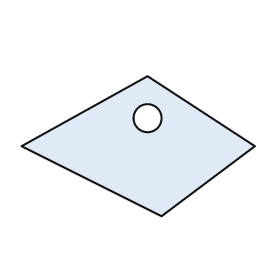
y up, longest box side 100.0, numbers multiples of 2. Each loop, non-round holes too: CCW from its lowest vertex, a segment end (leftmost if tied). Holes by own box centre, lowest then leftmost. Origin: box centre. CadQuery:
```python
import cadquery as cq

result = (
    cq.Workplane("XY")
    .moveTo(10.0, -30.0)
    .lineTo(50.0, 0.0)
    .lineTo(4.0, 30.0)
    .lineTo(-50.0, 0.0)
    .close()
    .moveTo(4.0, 12.0)
    .circle(6.0)
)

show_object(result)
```